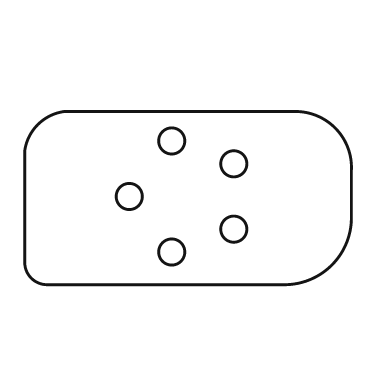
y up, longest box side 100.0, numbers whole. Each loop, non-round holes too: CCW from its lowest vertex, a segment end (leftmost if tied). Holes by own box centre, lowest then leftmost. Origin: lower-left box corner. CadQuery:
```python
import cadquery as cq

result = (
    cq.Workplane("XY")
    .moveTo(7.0, 0.0)
    .lineTo(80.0, 0.0)
    .threePointArc((94.0, 6.0), (100.0, 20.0))
    .lineTo(100.0, 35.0)
    .threePointArc((95.0, 48.0), (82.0, 53.0))
    .lineTo(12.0, 53.0)
    .threePointArc((4.0, 49.0), (0.0, 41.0))
    .lineTo(0.0, 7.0)
    .threePointArc((2.0, 2.0), (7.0, 0.0))
    .close()
    .moveTo(45.0, 10.0)
    .circle(4.0)
    .moveTo(64.0, 17.0)
    .circle(4.0)
    .moveTo(32.0, 27.0)
    .circle(4.0)
    .moveTo(64.0, 37.0)
    .circle(4.0)
    .moveTo(45.0, 44.0)
    .circle(4.0)
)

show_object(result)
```